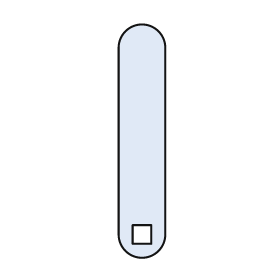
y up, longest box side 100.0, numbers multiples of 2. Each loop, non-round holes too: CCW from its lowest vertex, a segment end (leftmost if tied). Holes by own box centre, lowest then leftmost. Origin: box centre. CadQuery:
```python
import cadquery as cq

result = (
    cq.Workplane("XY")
    .moveTo(-10.0, -40.0)
    .threePointArc((0.0, -50.0), (10.0, -40.0))
    .lineTo(10.0, 40.0)
    .threePointArc((0.0, 50.0), (-10.0, 40.0))
    .close()
    .moveTo(-4.0, -44.0)
    .lineTo(4.0, -44.0)
    .lineTo(4.0, -36.0)
    .lineTo(-4.0, -36.0)
    .close()
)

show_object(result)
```